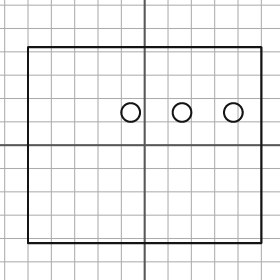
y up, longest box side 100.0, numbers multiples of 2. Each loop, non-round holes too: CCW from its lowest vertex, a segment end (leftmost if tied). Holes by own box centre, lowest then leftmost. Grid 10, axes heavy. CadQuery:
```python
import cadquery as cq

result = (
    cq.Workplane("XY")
    .moveTo(-50.0, -42.0)
    .lineTo(50.0, -42.0)
    .lineTo(50.0, 42.0)
    .lineTo(-50.0, 42.0)
    .close()
    .moveTo(-6.0, 14.0)
    .circle(4.0)
    .moveTo(16.0, 14.0)
    .circle(4.0)
    .moveTo(38.0, 14.0)
    .circle(4.0)
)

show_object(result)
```